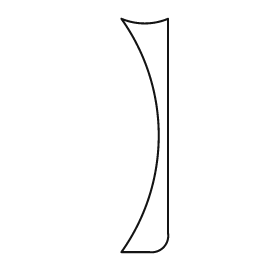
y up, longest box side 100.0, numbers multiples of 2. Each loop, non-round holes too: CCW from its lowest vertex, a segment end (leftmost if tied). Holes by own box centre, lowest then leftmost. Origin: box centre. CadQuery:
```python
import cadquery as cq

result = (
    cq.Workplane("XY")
    .moveTo(-10.0, -50.0)
    .lineTo(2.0, -50.0)
    .threePointArc((8.0, -48.0), (10.0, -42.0))
    .lineTo(10.0, 50.0)
    .threePointArc((0.0, 48.0), (-10.0, 50.0))
    .threePointArc((6.0, 0.0), (-10.0, -50.0))
    .close()
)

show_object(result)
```